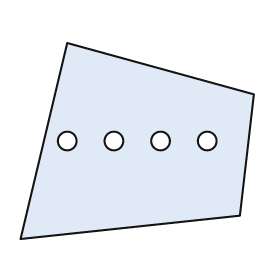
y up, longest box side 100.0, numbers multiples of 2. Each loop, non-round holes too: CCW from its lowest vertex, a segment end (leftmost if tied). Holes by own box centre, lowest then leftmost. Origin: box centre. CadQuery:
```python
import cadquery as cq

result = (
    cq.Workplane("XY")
    .moveTo(-50.0, -42.0)
    .lineTo(44.0, -32.0)
    .lineTo(50.0, 20.0)
    .lineTo(-30.0, 42.0)
    .close()
    .moveTo(-30.0, 0.0)
    .circle(4.0)
    .moveTo(-10.0, 0.0)
    .circle(4.0)
    .moveTo(10.0, 0.0)
    .circle(4.0)
    .moveTo(30.0, 0.0)
    .circle(4.0)
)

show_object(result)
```